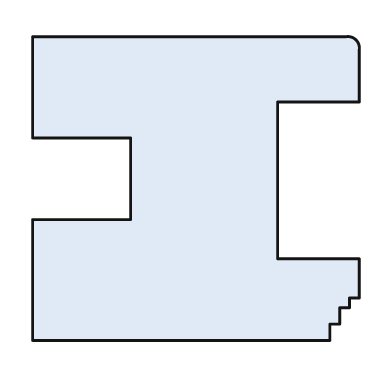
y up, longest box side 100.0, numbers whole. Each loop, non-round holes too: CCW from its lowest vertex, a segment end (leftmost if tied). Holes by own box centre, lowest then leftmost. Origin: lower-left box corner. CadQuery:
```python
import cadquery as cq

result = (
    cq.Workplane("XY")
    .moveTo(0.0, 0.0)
    .lineTo(91.0, 0.0)
    .lineTo(91.0, 5.0)
    .lineTo(94.0, 5.0)
    .lineTo(94.0, 10.0)
    .lineTo(97.0, 10.0)
    .lineTo(97.0, 13.0)
    .lineTo(100.0, 13.0)
    .lineTo(100.0, 25.0)
    .lineTo(75.0, 25.0)
    .lineTo(75.0, 73.0)
    .lineTo(100.0, 73.0)
    .lineTo(100.0, 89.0)
    .threePointArc((99.0, 92.0), (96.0, 93.0))
    .lineTo(0.0, 93.0)
    .lineTo(0.0, 62.0)
    .lineTo(30.0, 62.0)
    .lineTo(30.0, 37.0)
    .lineTo(0.0, 37.0)
    .close()
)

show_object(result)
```